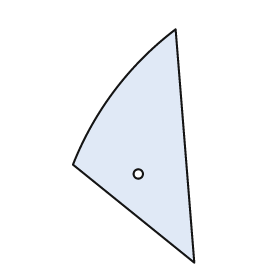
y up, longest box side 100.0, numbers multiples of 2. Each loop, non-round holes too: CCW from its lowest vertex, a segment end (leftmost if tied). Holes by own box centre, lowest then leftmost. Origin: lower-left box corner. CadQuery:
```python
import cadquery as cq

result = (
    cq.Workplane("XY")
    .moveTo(52.0, 0.0)
    .lineTo(44.0, 100.0)
    .threePointArc((18.0, 74.0), (0.0, 42.0))
    .close()
    .moveTo(28.0, 38.0)
    .circle(2.0)
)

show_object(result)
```